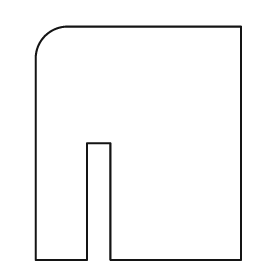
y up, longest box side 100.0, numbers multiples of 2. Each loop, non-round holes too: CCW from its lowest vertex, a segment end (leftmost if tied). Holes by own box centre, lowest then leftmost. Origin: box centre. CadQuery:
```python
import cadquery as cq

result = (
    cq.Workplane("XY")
    .moveTo(-44.0, -50.0)
    .lineTo(-22.0, -50.0)
    .lineTo(-22.0, 0.0)
    .lineTo(-12.0, 0.0)
    .lineTo(-12.0, -50.0)
    .lineTo(44.0, -50.0)
    .lineTo(44.0, 50.0)
    .lineTo(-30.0, 50.0)
    .threePointArc((-40.0, 46.0), (-44.0, 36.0))
    .close()
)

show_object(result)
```